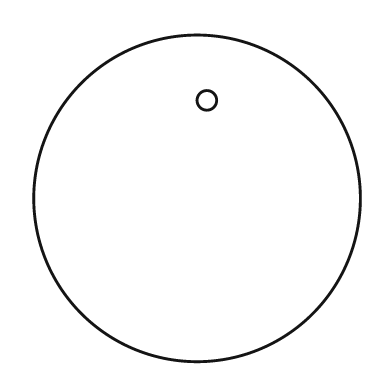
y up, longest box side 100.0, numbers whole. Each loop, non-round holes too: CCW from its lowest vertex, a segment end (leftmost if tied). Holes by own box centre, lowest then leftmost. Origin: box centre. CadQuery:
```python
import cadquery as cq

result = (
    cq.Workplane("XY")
    .moveTo(0.0, 0.0)
    .circle(50.0)
    .moveTo(3.0, 30.0)
    .circle(3.0)
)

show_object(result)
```